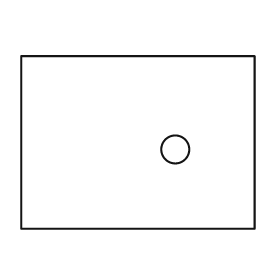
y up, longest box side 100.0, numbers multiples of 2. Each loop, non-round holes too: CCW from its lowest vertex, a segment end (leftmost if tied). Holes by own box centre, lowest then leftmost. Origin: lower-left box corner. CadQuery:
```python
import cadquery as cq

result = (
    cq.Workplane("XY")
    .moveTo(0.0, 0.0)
    .lineTo(100.0, 0.0)
    .lineTo(100.0, 74.0)
    .lineTo(0.0, 74.0)
    .close()
    .moveTo(66.0, 34.0)
    .circle(6.0)
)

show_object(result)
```